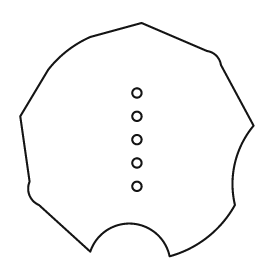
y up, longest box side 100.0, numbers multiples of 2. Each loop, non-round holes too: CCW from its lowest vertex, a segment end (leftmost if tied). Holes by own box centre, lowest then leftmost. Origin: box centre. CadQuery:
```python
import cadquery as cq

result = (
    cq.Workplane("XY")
    .moveTo(14.0, -50.0)
    .threePointArc((30.0, -42.0), (42.0, -28.0))
    .threePointArc((42.0, -10.0), (50.0, 6.0))
    .lineTo(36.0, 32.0)
    .threePointArc((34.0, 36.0), (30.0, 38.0))
    .lineTo(2.0, 50.0)
    .lineTo(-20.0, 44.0)
    .threePointArc((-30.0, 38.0), (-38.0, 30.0))
    .lineTo(-50.0, 10.0)
    .lineTo(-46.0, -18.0)
    .threePointArc((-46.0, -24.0), (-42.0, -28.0))
    .lineTo(-20.0, -48.0)
    .threePointArc((-2.0, -36.0), (14.0, -50.0))
    .close()
    .moveTo(0.0, -20.0)
    .circle(2.0)
    .moveTo(0.0, -10.0)
    .circle(2.0)
    .moveTo(0.0, 0.0)
    .circle(2.0)
    .moveTo(0.0, 10.0)
    .circle(2.0)
    .moveTo(0.0, 20.0)
    .circle(2.0)
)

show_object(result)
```